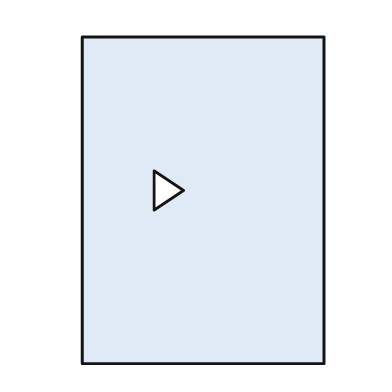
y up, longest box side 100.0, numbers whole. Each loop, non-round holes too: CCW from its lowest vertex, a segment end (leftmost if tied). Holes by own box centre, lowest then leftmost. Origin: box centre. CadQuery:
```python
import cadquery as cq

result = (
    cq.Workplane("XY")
    .moveTo(-37.0, -50.0)
    .lineTo(37.0, -50.0)
    .lineTo(37.0, 50.0)
    .lineTo(-37.0, 50.0)
    .close()
    .moveTo(-15.0, -3.0)
    .lineTo(-6.0, 3.0)
    .lineTo(-15.0, 9.0)
    .close()
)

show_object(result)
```